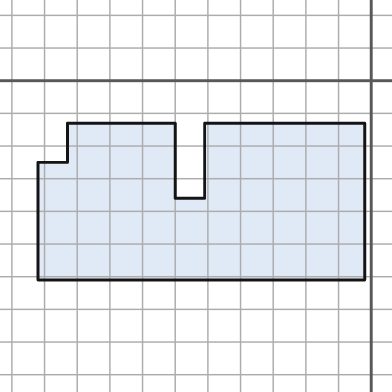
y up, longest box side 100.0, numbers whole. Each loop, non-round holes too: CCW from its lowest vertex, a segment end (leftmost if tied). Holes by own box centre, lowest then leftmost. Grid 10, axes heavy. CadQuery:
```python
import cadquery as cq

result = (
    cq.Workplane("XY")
    .moveTo(-102.0, -61.0)
    .lineTo(-2.0, -61.0)
    .lineTo(-2.0, -13.0)
    .lineTo(-51.0, -13.0)
    .lineTo(-51.0, -36.0)
    .lineTo(-60.0, -36.0)
    .lineTo(-60.0, -13.0)
    .lineTo(-93.0, -13.0)
    .lineTo(-93.0, -25.0)
    .lineTo(-102.0, -25.0)
    .close()
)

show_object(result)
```